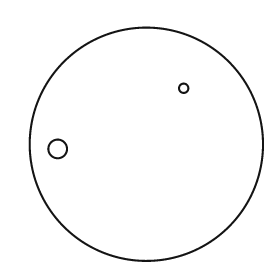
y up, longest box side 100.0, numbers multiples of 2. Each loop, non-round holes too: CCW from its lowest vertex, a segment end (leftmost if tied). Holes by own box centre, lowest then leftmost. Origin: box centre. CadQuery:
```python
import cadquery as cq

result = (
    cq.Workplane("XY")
    .moveTo(0.0, 0.0)
    .circle(50.0)
    .moveTo(-38.0, -2.0)
    .circle(4.0)
    .moveTo(16.0, 24.0)
    .circle(2.0)
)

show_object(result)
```